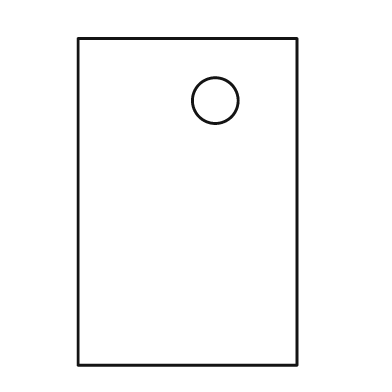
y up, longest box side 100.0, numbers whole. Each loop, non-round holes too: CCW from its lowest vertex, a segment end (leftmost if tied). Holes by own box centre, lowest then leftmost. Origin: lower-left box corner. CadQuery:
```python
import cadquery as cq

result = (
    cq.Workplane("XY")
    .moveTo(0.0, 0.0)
    .lineTo(67.0, 0.0)
    .lineTo(67.0, 100.0)
    .lineTo(0.0, 100.0)
    .close()
    .moveTo(42.0, 81.0)
    .circle(7.0)
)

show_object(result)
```